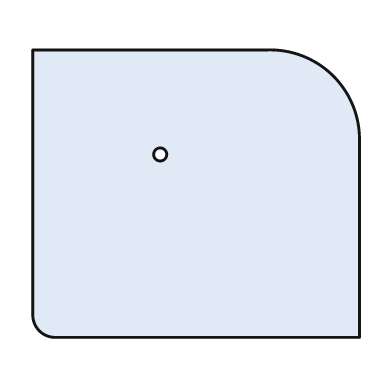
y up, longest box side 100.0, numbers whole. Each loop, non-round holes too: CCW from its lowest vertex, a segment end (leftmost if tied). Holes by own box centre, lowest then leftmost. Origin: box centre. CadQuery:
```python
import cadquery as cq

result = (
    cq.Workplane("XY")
    .moveTo(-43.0, -44.0)
    .lineTo(50.0, -44.0)
    .lineTo(50.0, 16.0)
    .threePointArc((42.0, 36.0), (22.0, 44.0))
    .lineTo(-50.0, 44.0)
    .lineTo(-50.0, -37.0)
    .threePointArc((-48.0, -42.0), (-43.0, -44.0))
    .close()
    .moveTo(-11.0, 12.0)
    .circle(2.0)
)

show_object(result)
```